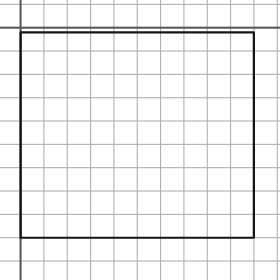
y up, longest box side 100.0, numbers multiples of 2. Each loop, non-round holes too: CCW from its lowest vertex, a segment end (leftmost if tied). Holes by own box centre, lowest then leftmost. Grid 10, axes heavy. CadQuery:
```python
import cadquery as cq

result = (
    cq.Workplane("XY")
    .moveTo(0.0, -90.0)
    .lineTo(100.0, -90.0)
    .lineTo(100.0, -2.0)
    .lineTo(0.0, -2.0)
    .close()
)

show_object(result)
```